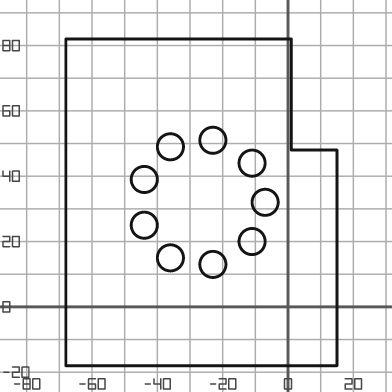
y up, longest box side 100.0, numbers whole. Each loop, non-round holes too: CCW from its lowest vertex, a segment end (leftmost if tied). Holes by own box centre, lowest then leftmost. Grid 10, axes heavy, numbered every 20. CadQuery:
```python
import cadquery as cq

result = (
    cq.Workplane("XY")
    .moveTo(-68.0, -18.0)
    .lineTo(15.0, -18.0)
    .lineTo(15.0, 48.0)
    .lineTo(1.0, 48.0)
    .lineTo(1.0, 82.0)
    .lineTo(-68.0, 82.0)
    .close()
    .moveTo(-23.0, 13.0)
    .circle(4.0)
    .moveTo(-36.0, 15.0)
    .circle(4.0)
    .moveTo(-11.0, 20.0)
    .circle(4.0)
    .moveTo(-44.0, 25.0)
    .circle(4.0)
    .moveTo(-7.0, 32.0)
    .circle(4.0)
    .moveTo(-44.0, 39.0)
    .circle(4.0)
    .moveTo(-11.0, 44.0)
    .circle(4.0)
    .moveTo(-36.0, 49.0)
    .circle(4.0)
    .moveTo(-23.0, 51.0)
    .circle(4.0)
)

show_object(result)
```